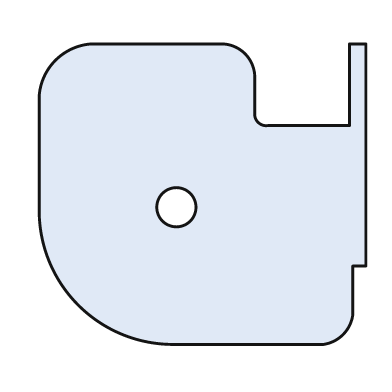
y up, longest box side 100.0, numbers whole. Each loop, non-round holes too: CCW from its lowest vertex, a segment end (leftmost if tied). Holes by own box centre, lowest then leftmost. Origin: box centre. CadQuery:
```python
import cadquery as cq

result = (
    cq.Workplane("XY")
    .moveTo(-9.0, -46.0)
    .lineTo(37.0, -46.0)
    .threePointArc((43.0, -43.0), (46.0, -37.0))
    .lineTo(46.0, -22.0)
    .lineTo(50.0, -22.0)
    .lineTo(50.0, 46.0)
    .lineTo(45.0, 46.0)
    .lineTo(45.0, 21.0)
    .lineTo(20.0, 21.0)
    .threePointArc((17.0, 22.0), (16.0, 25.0))
    .lineTo(16.0, 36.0)
    .threePointArc((13.0, 43.0), (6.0, 46.0))
    .lineTo(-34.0, 46.0)
    .threePointArc((-45.0, 41.0), (-50.0, 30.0))
    .lineTo(-50.0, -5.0)
    .threePointArc((-38.0, -34.0), (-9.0, -46.0))
    .close()
    .moveTo(-8.0, -4.0)
    .circle(6.0)
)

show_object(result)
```